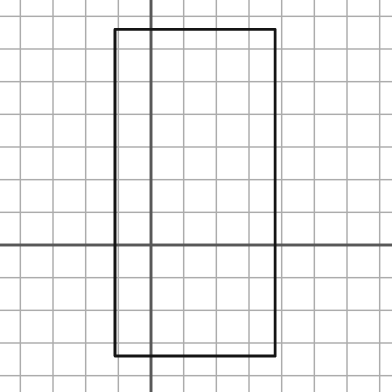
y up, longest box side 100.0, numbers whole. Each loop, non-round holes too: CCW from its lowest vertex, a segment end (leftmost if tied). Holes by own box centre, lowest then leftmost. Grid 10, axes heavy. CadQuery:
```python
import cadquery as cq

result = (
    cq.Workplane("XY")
    .moveTo(-11.0, -34.0)
    .lineTo(38.0, -34.0)
    .lineTo(38.0, 66.0)
    .lineTo(-11.0, 66.0)
    .close()
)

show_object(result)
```